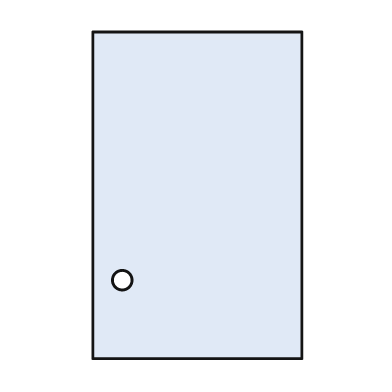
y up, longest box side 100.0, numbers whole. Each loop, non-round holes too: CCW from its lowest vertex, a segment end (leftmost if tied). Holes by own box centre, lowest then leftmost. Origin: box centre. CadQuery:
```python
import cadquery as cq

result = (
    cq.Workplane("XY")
    .moveTo(-32.0, -50.0)
    .lineTo(32.0, -50.0)
    .lineTo(32.0, 50.0)
    .lineTo(-32.0, 50.0)
    .close()
    .moveTo(-23.0, -26.0)
    .circle(3.0)
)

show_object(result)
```